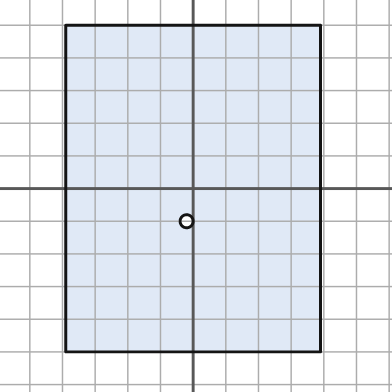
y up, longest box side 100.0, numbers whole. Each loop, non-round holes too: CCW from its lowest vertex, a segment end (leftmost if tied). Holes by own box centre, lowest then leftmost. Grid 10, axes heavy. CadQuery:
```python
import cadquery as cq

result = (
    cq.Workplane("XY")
    .moveTo(-39.0, -50.0)
    .lineTo(39.0, -50.0)
    .lineTo(39.0, 50.0)
    .lineTo(-39.0, 50.0)
    .close()
    .moveTo(-2.0, -10.0)
    .circle(2.0)
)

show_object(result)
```